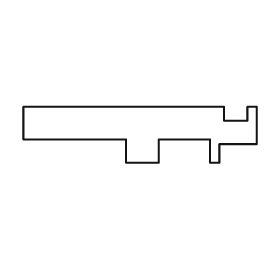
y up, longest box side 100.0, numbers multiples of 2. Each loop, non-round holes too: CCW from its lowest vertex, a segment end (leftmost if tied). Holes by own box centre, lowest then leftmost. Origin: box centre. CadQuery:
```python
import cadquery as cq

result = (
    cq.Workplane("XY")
    .moveTo(-6.0, -12.0)
    .lineTo(8.0, -12.0)
    .lineTo(8.0, -2.0)
    .lineTo(30.0, -2.0)
    .lineTo(30.0, -12.0)
    .lineTo(34.0, -12.0)
    .lineTo(34.0, -4.0)
    .lineTo(50.0, -4.0)
    .lineTo(50.0, 12.0)
    .lineTo(46.0, 12.0)
    .lineTo(46.0, 6.0)
    .lineTo(36.0, 6.0)
    .lineTo(36.0, 12.0)
    .lineTo(-50.0, 12.0)
    .lineTo(-50.0, -2.0)
    .lineTo(-6.0, -2.0)
    .close()
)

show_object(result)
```